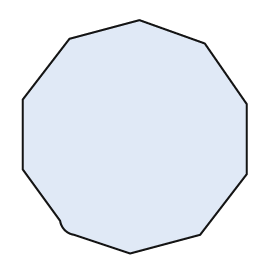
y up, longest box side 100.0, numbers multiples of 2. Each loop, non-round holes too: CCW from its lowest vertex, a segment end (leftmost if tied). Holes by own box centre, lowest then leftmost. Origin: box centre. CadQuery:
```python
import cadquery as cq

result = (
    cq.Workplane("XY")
    .moveTo(-2.0, -50.0)
    .lineTo(28.0, -42.0)
    .lineTo(48.0, -16.0)
    .lineTo(48.0, 14.0)
    .lineTo(30.0, 40.0)
    .lineTo(2.0, 50.0)
    .lineTo(-28.0, 42.0)
    .lineTo(-48.0, 16.0)
    .lineTo(-48.0, -14.0)
    .lineTo(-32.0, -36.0)
    .threePointArc((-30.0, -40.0), (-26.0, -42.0))
    .close()
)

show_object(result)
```